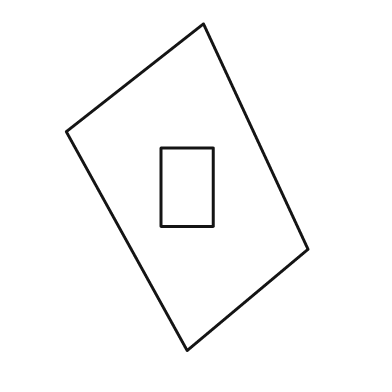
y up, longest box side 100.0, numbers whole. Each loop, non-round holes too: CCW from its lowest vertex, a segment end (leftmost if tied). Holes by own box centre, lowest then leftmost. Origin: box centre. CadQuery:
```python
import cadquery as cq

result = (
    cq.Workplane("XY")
    .moveTo(0.0, -50.0)
    .lineTo(37.0, -19.0)
    .lineTo(5.0, 50.0)
    .lineTo(-37.0, 17.0)
    .close()
    .moveTo(-8.0, -12.0)
    .lineTo(8.0, -12.0)
    .lineTo(8.0, 12.0)
    .lineTo(-8.0, 12.0)
    .close()
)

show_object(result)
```